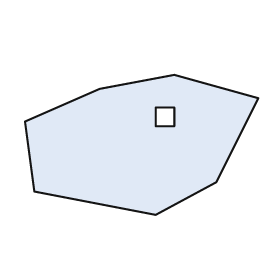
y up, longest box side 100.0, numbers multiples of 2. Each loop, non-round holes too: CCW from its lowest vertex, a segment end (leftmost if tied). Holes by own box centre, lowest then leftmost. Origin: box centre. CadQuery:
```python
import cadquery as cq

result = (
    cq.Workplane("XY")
    .moveTo(6.0, -30.0)
    .lineTo(32.0, -16.0)
    .lineTo(50.0, 20.0)
    .lineTo(14.0, 30.0)
    .lineTo(-18.0, 24.0)
    .lineTo(-50.0, 10.0)
    .lineTo(-46.0, -20.0)
    .close()
    .moveTo(6.0, 8.0)
    .lineTo(14.0, 8.0)
    .lineTo(14.0, 16.0)
    .lineTo(6.0, 16.0)
    .close()
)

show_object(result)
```